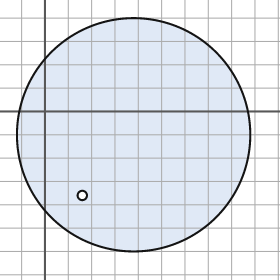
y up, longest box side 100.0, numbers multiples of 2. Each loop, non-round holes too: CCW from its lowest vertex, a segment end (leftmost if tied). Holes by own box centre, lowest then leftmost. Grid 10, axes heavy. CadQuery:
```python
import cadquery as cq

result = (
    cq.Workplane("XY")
    .moveTo(38.0, -10.0)
    .circle(50.0)
    .moveTo(16.0, -36.0)
    .circle(2.0)
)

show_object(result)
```